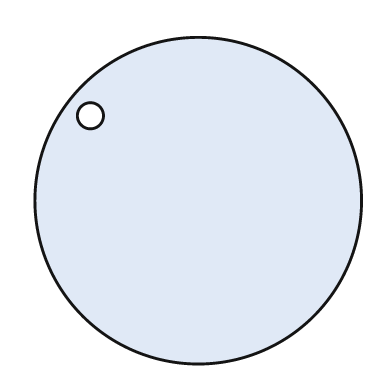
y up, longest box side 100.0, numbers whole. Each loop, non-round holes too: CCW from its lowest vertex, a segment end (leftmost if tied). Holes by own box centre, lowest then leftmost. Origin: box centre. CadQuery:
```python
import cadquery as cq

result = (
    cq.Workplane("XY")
    .moveTo(0.0, 0.0)
    .circle(50.0)
    .moveTo(-33.0, 26.0)
    .circle(4.0)
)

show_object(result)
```